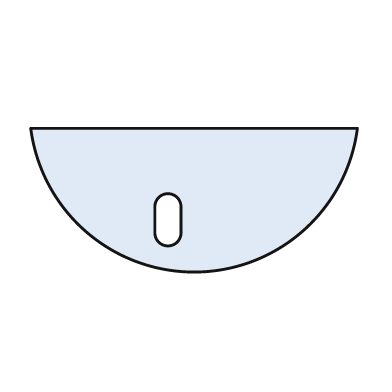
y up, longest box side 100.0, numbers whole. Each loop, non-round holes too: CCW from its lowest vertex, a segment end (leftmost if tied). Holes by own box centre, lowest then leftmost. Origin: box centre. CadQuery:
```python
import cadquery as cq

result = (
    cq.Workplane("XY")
    .moveTo(-50.0, 22.0)
    .threePointArc((0.0, -22.0), (50.0, 22.0))
    .close()
    .moveTo(-12.0, -10.0)
    .threePointArc((-8.0, -14.0), (-4.0, -10.0))
    .lineTo(-4.0, -2.0)
    .threePointArc((-8.0, 2.0), (-12.0, -2.0))
    .close()
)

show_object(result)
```